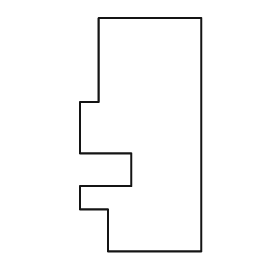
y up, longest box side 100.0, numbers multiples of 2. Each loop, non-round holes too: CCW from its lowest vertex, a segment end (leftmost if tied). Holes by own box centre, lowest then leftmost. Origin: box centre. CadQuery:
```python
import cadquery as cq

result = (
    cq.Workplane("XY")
    .moveTo(-14.0, -50.0)
    .lineTo(26.0, -50.0)
    .lineTo(26.0, 50.0)
    .lineTo(-18.0, 50.0)
    .lineTo(-18.0, 14.0)
    .lineTo(-26.0, 14.0)
    .lineTo(-26.0, -8.0)
    .lineTo(-4.0, -8.0)
    .lineTo(-4.0, -22.0)
    .lineTo(-26.0, -22.0)
    .lineTo(-26.0, -32.0)
    .lineTo(-14.0, -32.0)
    .close()
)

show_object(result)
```